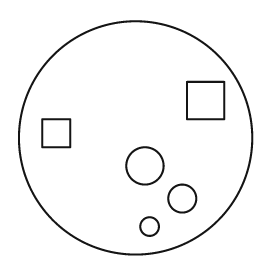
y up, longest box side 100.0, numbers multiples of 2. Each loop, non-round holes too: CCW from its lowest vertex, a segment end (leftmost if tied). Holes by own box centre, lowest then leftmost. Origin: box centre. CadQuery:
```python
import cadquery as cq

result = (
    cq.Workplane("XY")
    .moveTo(0.0, 0.0)
    .circle(50.0)
    .moveTo(6.0, -38.0)
    .circle(4.0)
    .moveTo(20.0, -26.0)
    .circle(6.0)
    .moveTo(4.0, -12.0)
    .circle(8.0)
    .moveTo(-40.0, -4.0)
    .lineTo(-28.0, -4.0)
    .lineTo(-28.0, 8.0)
    .lineTo(-40.0, 8.0)
    .close()
    .moveTo(22.0, 8.0)
    .lineTo(38.0, 8.0)
    .lineTo(38.0, 24.0)
    .lineTo(22.0, 24.0)
    .close()
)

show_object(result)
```